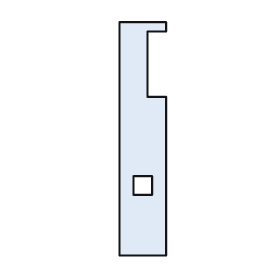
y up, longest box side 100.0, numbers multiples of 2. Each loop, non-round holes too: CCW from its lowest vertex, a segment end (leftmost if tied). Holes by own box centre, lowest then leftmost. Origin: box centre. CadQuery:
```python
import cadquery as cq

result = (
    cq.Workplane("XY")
    .moveTo(-10.0, -50.0)
    .lineTo(10.0, -50.0)
    .lineTo(10.0, 18.0)
    .lineTo(2.0, 18.0)
    .lineTo(2.0, 46.0)
    .lineTo(10.0, 46.0)
    .lineTo(10.0, 50.0)
    .lineTo(-10.0, 50.0)
    .close()
    .moveTo(-4.0, -24.0)
    .lineTo(4.0, -24.0)
    .lineTo(4.0, -16.0)
    .lineTo(-4.0, -16.0)
    .close()
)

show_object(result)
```